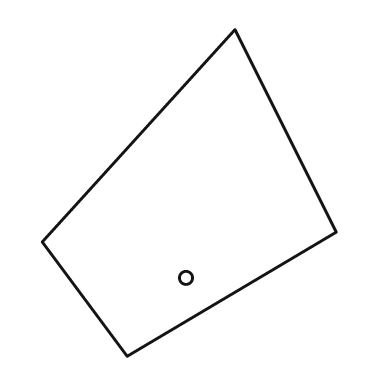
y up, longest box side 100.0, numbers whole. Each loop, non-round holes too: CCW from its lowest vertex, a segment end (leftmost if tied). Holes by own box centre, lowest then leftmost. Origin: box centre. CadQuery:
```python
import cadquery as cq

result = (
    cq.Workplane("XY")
    .moveTo(-19.0, -50.0)
    .lineTo(45.0, -12.0)
    .lineTo(14.0, 50.0)
    .lineTo(-45.0, -15.0)
    .close()
    .moveTo(-1.0, -26.0)
    .circle(2.0)
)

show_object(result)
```